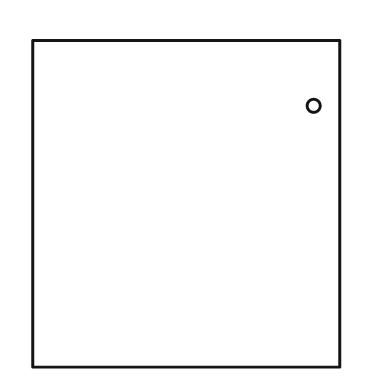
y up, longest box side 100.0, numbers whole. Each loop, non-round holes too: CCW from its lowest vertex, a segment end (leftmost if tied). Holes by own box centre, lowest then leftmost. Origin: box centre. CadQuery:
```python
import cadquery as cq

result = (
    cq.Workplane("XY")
    .moveTo(-47.0, -50.0)
    .lineTo(47.0, -50.0)
    .lineTo(47.0, 50.0)
    .lineTo(-47.0, 50.0)
    .close()
    .moveTo(39.0, 30.0)
    .circle(2.0)
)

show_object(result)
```